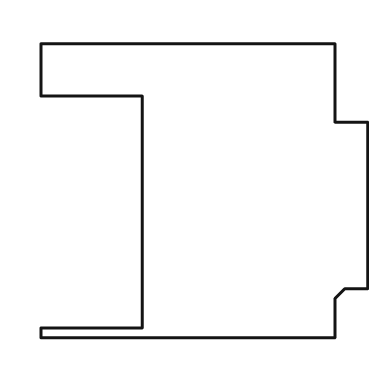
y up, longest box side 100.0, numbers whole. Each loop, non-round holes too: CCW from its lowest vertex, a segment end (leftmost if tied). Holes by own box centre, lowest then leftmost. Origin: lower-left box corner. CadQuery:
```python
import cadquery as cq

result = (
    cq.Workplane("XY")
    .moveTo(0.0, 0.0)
    .lineTo(90.0, 0.0)
    .lineTo(90.0, 12.0)
    .lineTo(93.0, 15.0)
    .lineTo(100.0, 15.0)
    .lineTo(100.0, 66.0)
    .lineTo(90.0, 66.0)
    .lineTo(90.0, 90.0)
    .lineTo(0.0, 90.0)
    .lineTo(0.0, 74.0)
    .lineTo(31.0, 74.0)
    .lineTo(31.0, 3.0)
    .lineTo(0.0, 3.0)
    .close()
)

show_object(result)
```